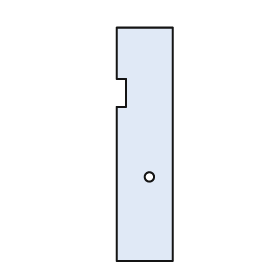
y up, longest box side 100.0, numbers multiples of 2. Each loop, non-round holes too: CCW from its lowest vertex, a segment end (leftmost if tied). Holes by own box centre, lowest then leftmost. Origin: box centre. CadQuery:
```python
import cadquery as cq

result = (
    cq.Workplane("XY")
    .moveTo(-12.0, -50.0)
    .lineTo(12.0, -50.0)
    .lineTo(12.0, 50.0)
    .lineTo(-12.0, 50.0)
    .lineTo(-12.0, 28.0)
    .lineTo(-8.0, 28.0)
    .lineTo(-8.0, 16.0)
    .lineTo(-12.0, 16.0)
    .close()
    .moveTo(2.0, -14.0)
    .circle(2.0)
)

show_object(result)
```